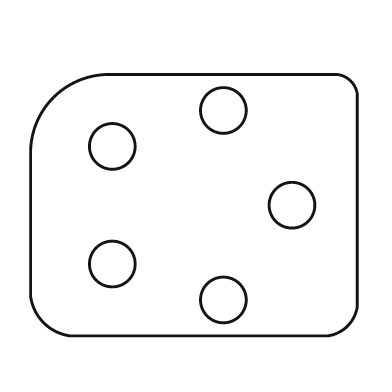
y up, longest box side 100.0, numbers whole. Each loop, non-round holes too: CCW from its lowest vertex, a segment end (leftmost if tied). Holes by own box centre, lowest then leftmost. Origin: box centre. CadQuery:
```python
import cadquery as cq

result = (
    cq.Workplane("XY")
    .moveTo(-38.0, -40.0)
    .lineTo(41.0, -40.0)
    .threePointArc((47.0, -37.0), (50.0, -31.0))
    .lineTo(50.0, 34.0)
    .threePointArc((48.0, 38.0), (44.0, 40.0))
    .lineTo(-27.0, 40.0)
    .threePointArc((-43.0, 33.0), (-50.0, 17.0))
    .lineTo(-50.0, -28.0)
    .threePointArc((-46.0, -36.0), (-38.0, -40.0))
    .close()
    .moveTo(9.0, -29.0)
    .circle(7.0)
    .moveTo(-25.0, -18.0)
    .circle(7.0)
    .moveTo(30.0, 0.0)
    .circle(7.0)
    .moveTo(-25.0, 18.0)
    .circle(7.0)
    .moveTo(9.0, 29.0)
    .circle(7.0)
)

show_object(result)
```